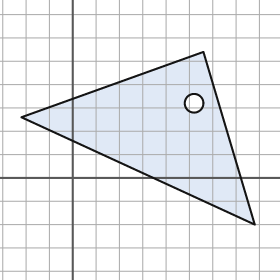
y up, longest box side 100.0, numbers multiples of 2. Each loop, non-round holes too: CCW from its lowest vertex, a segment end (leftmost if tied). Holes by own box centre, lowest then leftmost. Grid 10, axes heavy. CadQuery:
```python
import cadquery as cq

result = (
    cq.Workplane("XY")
    .moveTo(78.0, -20.0)
    .lineTo(56.0, 54.0)
    .lineTo(-22.0, 26.0)
    .close()
    .moveTo(52.0, 32.0)
    .circle(4.0)
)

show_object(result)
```